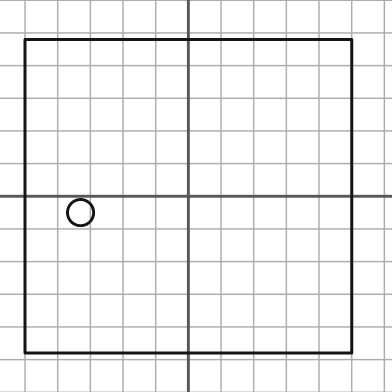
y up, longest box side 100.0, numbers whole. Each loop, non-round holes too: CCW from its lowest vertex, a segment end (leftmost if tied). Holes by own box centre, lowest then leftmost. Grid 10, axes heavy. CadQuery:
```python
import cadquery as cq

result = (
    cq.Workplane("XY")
    .moveTo(-50.0, -48.0)
    .lineTo(50.0, -48.0)
    .lineTo(50.0, 48.0)
    .lineTo(-50.0, 48.0)
    .close()
    .moveTo(-33.0, -5.0)
    .circle(4.0)
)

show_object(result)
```